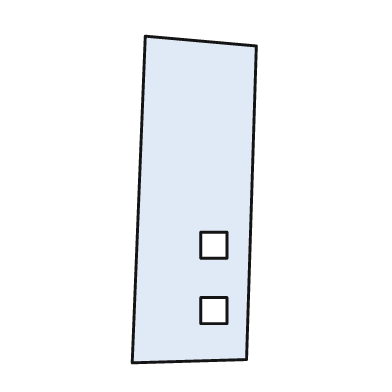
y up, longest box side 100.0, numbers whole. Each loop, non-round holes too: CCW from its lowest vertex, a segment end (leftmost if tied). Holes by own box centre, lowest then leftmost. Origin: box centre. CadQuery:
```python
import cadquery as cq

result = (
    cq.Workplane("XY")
    .moveTo(-19.0, -50.0)
    .lineTo(16.0, -49.0)
    .lineTo(19.0, 47.0)
    .lineTo(-15.0, 50.0)
    .close()
    .moveTo(2.0, -38.0)
    .lineTo(10.0, -38.0)
    .lineTo(10.0, -30.0)
    .lineTo(2.0, -30.0)
    .close()
    .moveTo(2.0, -18.0)
    .lineTo(10.0, -18.0)
    .lineTo(10.0, -10.0)
    .lineTo(2.0, -10.0)
    .close()
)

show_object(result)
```